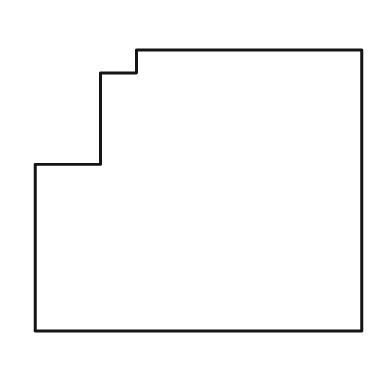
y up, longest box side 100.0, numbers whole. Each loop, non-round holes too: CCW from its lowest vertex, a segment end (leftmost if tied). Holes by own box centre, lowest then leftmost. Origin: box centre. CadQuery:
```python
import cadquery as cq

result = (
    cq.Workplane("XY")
    .moveTo(-50.0, -43.0)
    .lineTo(50.0, -43.0)
    .lineTo(50.0, 43.0)
    .lineTo(-19.0, 43.0)
    .lineTo(-19.0, 36.0)
    .lineTo(-30.0, 36.0)
    .lineTo(-30.0, 8.0)
    .lineTo(-50.0, 8.0)
    .close()
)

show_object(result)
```